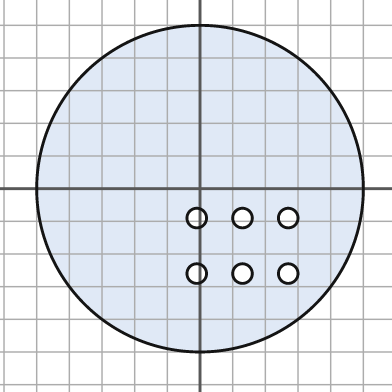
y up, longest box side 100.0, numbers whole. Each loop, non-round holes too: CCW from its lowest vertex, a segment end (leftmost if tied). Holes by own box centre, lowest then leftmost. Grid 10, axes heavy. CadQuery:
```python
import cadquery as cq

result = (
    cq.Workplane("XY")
    .moveTo(0.0, 0.0)
    .circle(50.0)
    .moveTo(-1.0, -26.0)
    .circle(3.0)
    .moveTo(13.0, -26.0)
    .circle(3.0)
    .moveTo(27.0, -26.0)
    .circle(3.0)
    .moveTo(-1.0, -9.0)
    .circle(3.0)
    .moveTo(13.0, -9.0)
    .circle(3.0)
    .moveTo(27.0, -9.0)
    .circle(3.0)
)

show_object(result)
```